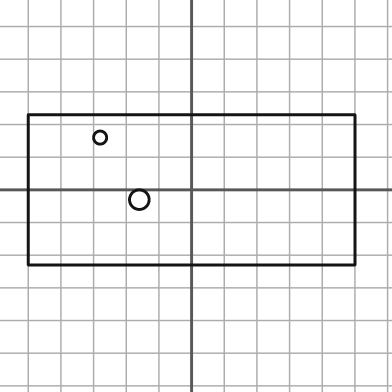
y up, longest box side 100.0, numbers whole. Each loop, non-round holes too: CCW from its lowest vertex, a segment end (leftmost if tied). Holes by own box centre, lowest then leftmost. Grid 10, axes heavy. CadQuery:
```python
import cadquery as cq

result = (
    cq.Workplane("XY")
    .moveTo(-50.0, -23.0)
    .lineTo(50.0, -23.0)
    .lineTo(50.0, 23.0)
    .lineTo(-50.0, 23.0)
    .close()
    .moveTo(-16.0, -3.0)
    .circle(3.0)
    .moveTo(-28.0, 16.0)
    .circle(2.0)
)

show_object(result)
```